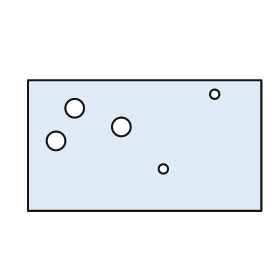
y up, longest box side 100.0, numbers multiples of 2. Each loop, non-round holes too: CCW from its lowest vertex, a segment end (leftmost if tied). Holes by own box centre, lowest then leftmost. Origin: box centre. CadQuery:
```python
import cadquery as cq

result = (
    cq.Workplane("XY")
    .moveTo(-50.0, -28.0)
    .lineTo(50.0, -28.0)
    .lineTo(50.0, 28.0)
    .lineTo(-50.0, 28.0)
    .close()
    .moveTo(8.0, -10.0)
    .circle(2.0)
    .moveTo(-38.0, 2.0)
    .circle(4.0)
    .moveTo(-10.0, 8.0)
    .circle(4.0)
    .moveTo(-30.0, 16.0)
    .circle(4.0)
    .moveTo(30.0, 22.0)
    .circle(2.0)
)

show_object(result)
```